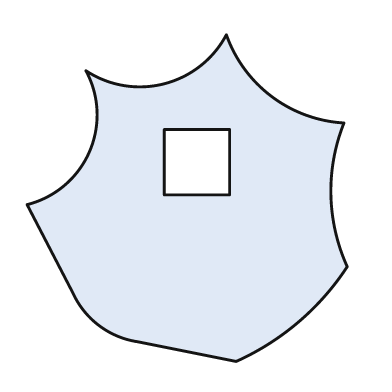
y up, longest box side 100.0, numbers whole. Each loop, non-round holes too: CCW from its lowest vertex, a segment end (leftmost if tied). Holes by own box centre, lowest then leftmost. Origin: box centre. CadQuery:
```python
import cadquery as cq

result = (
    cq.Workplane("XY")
    .moveTo(15.0, -50.0)
    .threePointArc((34.0, -38.0), (49.0, -21.0))
    .threePointArc((44.0, 1.0), (48.0, 23.0))
    .threePointArc((26.0, 31.0), (12.0, 50.0))
    .threePointArc((-7.0, 35.0), (-31.0, 39.0))
    .threePointArc((-30.0, 14.0), (-49.0, -2.0))
    .lineTo(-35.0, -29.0)
    .threePointArc((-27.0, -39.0), (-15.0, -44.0))
    .close()
    .moveTo(-7.0, 1.0)
    .lineTo(13.0, 1.0)
    .lineTo(13.0, 21.0)
    .lineTo(-7.0, 21.0)
    .close()
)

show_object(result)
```